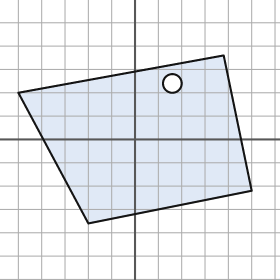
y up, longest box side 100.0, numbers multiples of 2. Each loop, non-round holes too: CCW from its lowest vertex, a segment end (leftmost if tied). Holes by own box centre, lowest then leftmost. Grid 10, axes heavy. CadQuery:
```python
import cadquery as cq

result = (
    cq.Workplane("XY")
    .moveTo(-20.0, -36.0)
    .lineTo(50.0, -22.0)
    .lineTo(38.0, 36.0)
    .lineTo(-50.0, 20.0)
    .close()
    .moveTo(16.0, 24.0)
    .circle(4.0)
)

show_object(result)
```